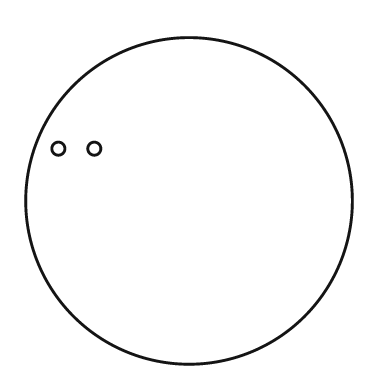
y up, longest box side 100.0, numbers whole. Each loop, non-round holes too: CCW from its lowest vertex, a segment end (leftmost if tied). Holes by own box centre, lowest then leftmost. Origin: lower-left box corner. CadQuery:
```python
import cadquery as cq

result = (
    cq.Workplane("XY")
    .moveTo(50.0, 50.0)
    .circle(50.0)
    .moveTo(10.0, 66.0)
    .circle(2.0)
    .moveTo(21.0, 66.0)
    .circle(2.0)
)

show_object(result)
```